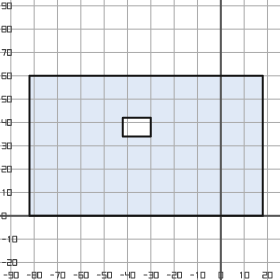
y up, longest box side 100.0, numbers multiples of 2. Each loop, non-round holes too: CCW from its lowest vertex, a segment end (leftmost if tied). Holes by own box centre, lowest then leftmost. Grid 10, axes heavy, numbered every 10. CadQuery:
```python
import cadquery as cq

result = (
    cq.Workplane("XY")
    .moveTo(-82.0, 0.0)
    .lineTo(18.0, 0.0)
    .lineTo(18.0, 60.0)
    .lineTo(-82.0, 60.0)
    .close()
    .moveTo(-42.0, 34.0)
    .lineTo(-30.0, 34.0)
    .lineTo(-30.0, 42.0)
    .lineTo(-42.0, 42.0)
    .close()
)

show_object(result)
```